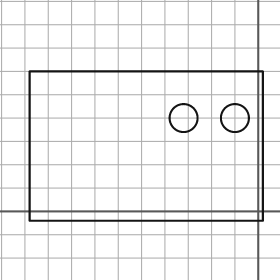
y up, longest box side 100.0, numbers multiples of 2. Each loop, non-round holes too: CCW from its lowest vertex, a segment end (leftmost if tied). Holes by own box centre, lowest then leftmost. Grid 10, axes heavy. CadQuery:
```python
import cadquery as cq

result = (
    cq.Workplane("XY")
    .moveTo(-98.0, -4.0)
    .lineTo(2.0, -4.0)
    .lineTo(2.0, 60.0)
    .lineTo(-98.0, 60.0)
    .close()
    .moveTo(-32.0, 40.0)
    .circle(6.0)
    .moveTo(-10.0, 40.0)
    .circle(6.0)
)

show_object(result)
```